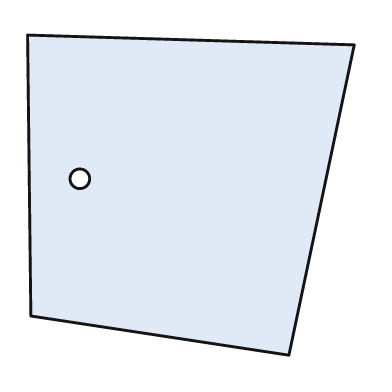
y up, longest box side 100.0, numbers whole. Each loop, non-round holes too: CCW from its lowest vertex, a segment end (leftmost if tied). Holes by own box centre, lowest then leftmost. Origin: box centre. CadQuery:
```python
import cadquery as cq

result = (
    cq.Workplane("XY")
    .moveTo(30.0, -49.0)
    .lineTo(50.0, 46.0)
    .lineTo(-50.0, 49.0)
    .lineTo(-49.0, -37.0)
    .close()
    .moveTo(-34.0, 5.0)
    .circle(3.0)
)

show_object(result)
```